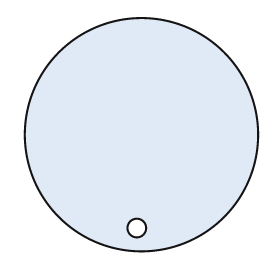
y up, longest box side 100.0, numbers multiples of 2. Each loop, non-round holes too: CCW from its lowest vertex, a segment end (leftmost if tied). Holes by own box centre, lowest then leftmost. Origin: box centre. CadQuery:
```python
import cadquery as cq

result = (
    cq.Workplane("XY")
    .moveTo(0.0, 0.0)
    .circle(50.0)
    .moveTo(-2.0, -40.0)
    .circle(4.0)
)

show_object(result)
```